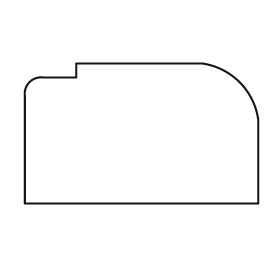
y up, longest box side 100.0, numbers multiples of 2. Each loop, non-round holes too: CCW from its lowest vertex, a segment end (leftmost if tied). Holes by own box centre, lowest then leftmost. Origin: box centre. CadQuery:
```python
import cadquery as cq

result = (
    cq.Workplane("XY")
    .moveTo(-50.0, -30.0)
    .lineTo(50.0, -30.0)
    .lineTo(50.0, 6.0)
    .threePointArc((42.0, 22.0), (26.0, 30.0))
    .lineTo(-28.0, 30.0)
    .lineTo(-28.0, 24.0)
    .lineTo(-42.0, 24.0)
    .threePointArc((-48.0, 22.0), (-50.0, 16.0))
    .close()
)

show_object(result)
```